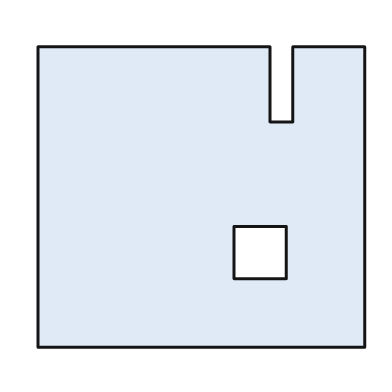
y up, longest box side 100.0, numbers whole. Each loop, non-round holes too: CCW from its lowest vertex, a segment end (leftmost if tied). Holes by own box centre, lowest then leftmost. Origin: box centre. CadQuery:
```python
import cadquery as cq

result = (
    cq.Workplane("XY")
    .moveTo(-50.0, -46.0)
    .lineTo(50.0, -46.0)
    .lineTo(50.0, 46.0)
    .lineTo(28.0, 46.0)
    .lineTo(28.0, 23.0)
    .lineTo(21.0, 23.0)
    .lineTo(21.0, 46.0)
    .lineTo(-50.0, 46.0)
    .close()
    .moveTo(10.0, -25.0)
    .lineTo(26.0, -25.0)
    .lineTo(26.0, -9.0)
    .lineTo(10.0, -9.0)
    .close()
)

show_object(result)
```